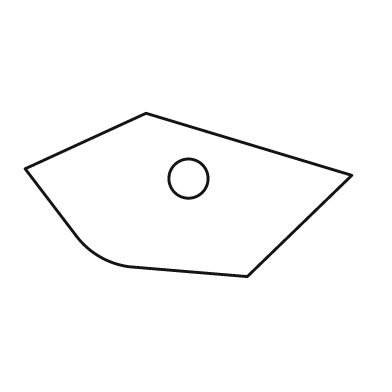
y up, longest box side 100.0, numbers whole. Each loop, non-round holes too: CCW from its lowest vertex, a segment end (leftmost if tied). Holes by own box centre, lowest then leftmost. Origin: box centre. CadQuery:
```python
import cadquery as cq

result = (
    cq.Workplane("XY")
    .moveTo(18.0, -25.0)
    .lineTo(50.0, 6.0)
    .lineTo(-13.0, 25.0)
    .lineTo(-50.0, 8.0)
    .lineTo(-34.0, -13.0)
    .threePointArc((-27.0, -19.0), (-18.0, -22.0))
    .close()
    .moveTo(0.0, 5.0)
    .circle(6.0)
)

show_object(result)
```